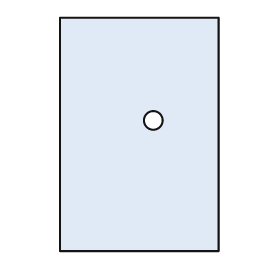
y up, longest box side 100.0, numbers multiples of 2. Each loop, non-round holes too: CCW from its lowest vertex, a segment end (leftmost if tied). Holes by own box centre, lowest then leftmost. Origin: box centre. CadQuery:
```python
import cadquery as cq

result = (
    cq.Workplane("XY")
    .moveTo(-34.0, -50.0)
    .lineTo(34.0, -50.0)
    .lineTo(34.0, 50.0)
    .lineTo(-34.0, 50.0)
    .close()
    .moveTo(6.0, 6.0)
    .circle(4.0)
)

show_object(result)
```